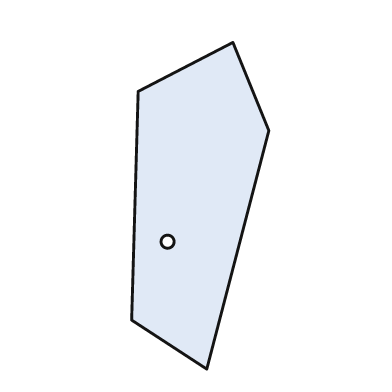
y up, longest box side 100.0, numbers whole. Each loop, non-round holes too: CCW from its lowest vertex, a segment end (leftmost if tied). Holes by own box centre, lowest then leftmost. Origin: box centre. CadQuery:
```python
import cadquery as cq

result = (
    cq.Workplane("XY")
    .moveTo(2.0, -50.0)
    .lineTo(21.0, 23.0)
    .lineTo(10.0, 50.0)
    .lineTo(-19.0, 35.0)
    .lineTo(-21.0, -35.0)
    .close()
    .moveTo(-10.0, -11.0)
    .circle(2.0)
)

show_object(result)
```